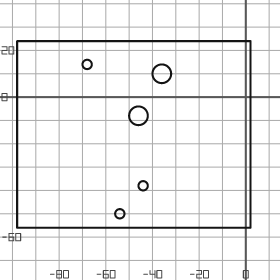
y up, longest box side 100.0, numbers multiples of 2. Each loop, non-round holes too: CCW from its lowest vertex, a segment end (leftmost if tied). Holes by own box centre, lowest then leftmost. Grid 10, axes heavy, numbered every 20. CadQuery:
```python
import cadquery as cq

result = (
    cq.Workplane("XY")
    .moveTo(-98.0, -56.0)
    .lineTo(2.0, -56.0)
    .lineTo(2.0, 24.0)
    .lineTo(-98.0, 24.0)
    .close()
    .moveTo(-54.0, -50.0)
    .circle(2.0)
    .moveTo(-44.0, -38.0)
    .circle(2.0)
    .moveTo(-46.0, -8.0)
    .circle(4.0)
    .moveTo(-36.0, 10.0)
    .circle(4.0)
    .moveTo(-68.0, 14.0)
    .circle(2.0)
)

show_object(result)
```